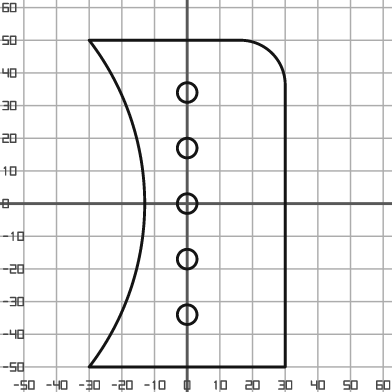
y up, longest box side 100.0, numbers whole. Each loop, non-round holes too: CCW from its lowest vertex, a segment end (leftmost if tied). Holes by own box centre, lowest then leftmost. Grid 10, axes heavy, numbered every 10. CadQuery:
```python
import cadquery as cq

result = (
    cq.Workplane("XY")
    .moveTo(-30.0, -50.0)
    .lineTo(30.0, -50.0)
    .lineTo(30.0, 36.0)
    .threePointArc((26.0, 46.0), (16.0, 50.0))
    .lineTo(-30.0, 50.0)
    .threePointArc((-13.0, 0.0), (-30.0, -50.0))
    .close()
    .moveTo(0.0, -34.0)
    .circle(3.0)
    .moveTo(0.0, -17.0)
    .circle(3.0)
    .moveTo(0.0, 0.0)
    .circle(3.0)
    .moveTo(0.0, 17.0)
    .circle(3.0)
    .moveTo(0.0, 34.0)
    .circle(3.0)
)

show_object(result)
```